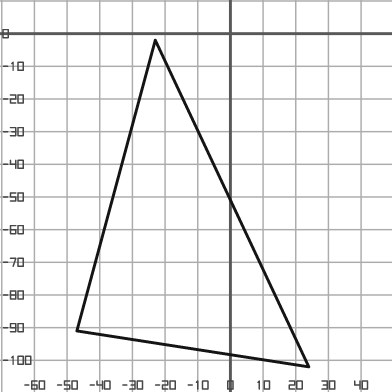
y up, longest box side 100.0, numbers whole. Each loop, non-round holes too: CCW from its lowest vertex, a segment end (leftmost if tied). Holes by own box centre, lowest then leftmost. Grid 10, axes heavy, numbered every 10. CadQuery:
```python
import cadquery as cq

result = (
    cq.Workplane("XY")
    .moveTo(24.0, -102.0)
    .lineTo(-23.0, -2.0)
    .lineTo(-47.0, -91.0)
    .close()
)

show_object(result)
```